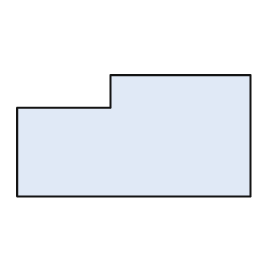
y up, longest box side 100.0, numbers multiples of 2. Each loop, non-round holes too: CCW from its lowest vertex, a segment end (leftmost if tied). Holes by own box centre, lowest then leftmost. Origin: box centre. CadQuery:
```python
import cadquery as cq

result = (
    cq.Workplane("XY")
    .moveTo(-50.0, -26.0)
    .lineTo(50.0, -26.0)
    .lineTo(50.0, 26.0)
    .lineTo(-10.0, 26.0)
    .lineTo(-10.0, 12.0)
    .lineTo(-50.0, 12.0)
    .close()
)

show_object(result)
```